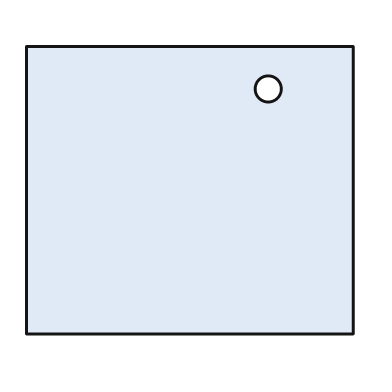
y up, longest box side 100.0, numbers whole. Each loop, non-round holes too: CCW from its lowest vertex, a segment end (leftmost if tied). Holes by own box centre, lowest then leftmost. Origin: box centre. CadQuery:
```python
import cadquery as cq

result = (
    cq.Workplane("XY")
    .moveTo(-50.0, -44.0)
    .lineTo(50.0, -44.0)
    .lineTo(50.0, 44.0)
    .lineTo(-50.0, 44.0)
    .close()
    .moveTo(24.0, 31.0)
    .circle(4.0)
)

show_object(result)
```